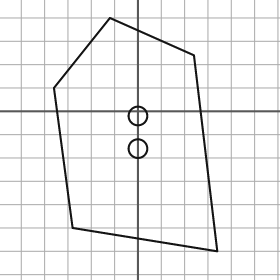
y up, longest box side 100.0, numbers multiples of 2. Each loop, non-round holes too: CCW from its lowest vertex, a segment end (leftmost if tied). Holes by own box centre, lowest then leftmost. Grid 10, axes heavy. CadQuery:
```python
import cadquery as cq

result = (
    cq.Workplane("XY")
    .moveTo(34.0, -60.0)
    .lineTo(24.0, 24.0)
    .lineTo(-12.0, 40.0)
    .lineTo(-36.0, 10.0)
    .lineTo(-28.0, -50.0)
    .close()
    .moveTo(0.0, -16.0)
    .circle(4.0)
    .moveTo(0.0, -2.0)
    .circle(4.0)
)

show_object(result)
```